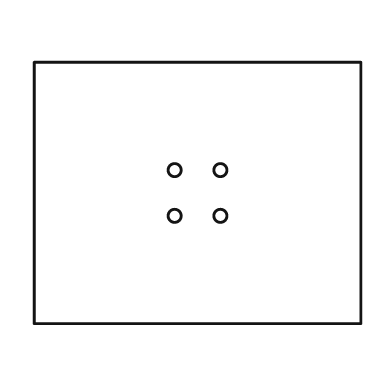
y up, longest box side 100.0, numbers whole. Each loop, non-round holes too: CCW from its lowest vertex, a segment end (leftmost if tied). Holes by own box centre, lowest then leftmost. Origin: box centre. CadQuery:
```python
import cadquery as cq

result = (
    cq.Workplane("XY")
    .moveTo(-50.0, -40.0)
    .lineTo(50.0, -40.0)
    .lineTo(50.0, 40.0)
    .lineTo(-50.0, 40.0)
    .close()
    .moveTo(-7.0, -7.0)
    .circle(2.0)
    .moveTo(7.0, -7.0)
    .circle(2.0)
    .moveTo(-7.0, 7.0)
    .circle(2.0)
    .moveTo(7.0, 7.0)
    .circle(2.0)
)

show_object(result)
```